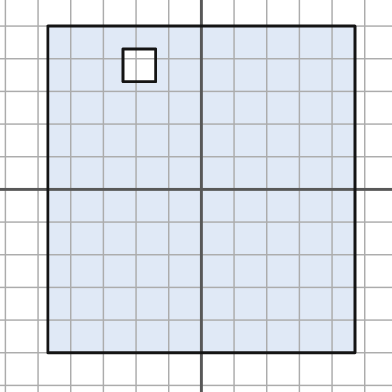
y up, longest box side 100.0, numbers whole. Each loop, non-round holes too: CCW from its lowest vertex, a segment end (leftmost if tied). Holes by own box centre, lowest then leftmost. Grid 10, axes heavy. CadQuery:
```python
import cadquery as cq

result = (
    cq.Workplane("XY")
    .moveTo(-47.0, -50.0)
    .lineTo(47.0, -50.0)
    .lineTo(47.0, 50.0)
    .lineTo(-47.0, 50.0)
    .close()
    .moveTo(-24.0, 33.0)
    .lineTo(-14.0, 33.0)
    .lineTo(-14.0, 43.0)
    .lineTo(-24.0, 43.0)
    .close()
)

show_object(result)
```